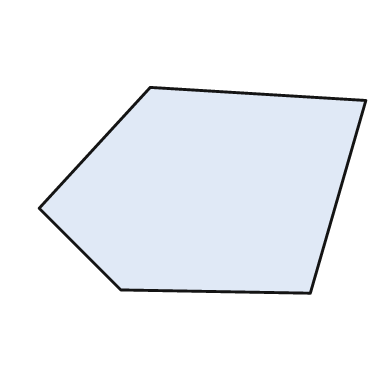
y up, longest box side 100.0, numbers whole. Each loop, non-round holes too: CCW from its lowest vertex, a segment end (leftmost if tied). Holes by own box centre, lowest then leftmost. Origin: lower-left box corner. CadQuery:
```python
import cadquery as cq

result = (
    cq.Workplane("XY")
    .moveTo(83.0, 0.0)
    .lineTo(100.0, 59.0)
    .lineTo(34.0, 63.0)
    .lineTo(0.0, 26.0)
    .lineTo(25.0, 1.0)
    .close()
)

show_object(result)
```